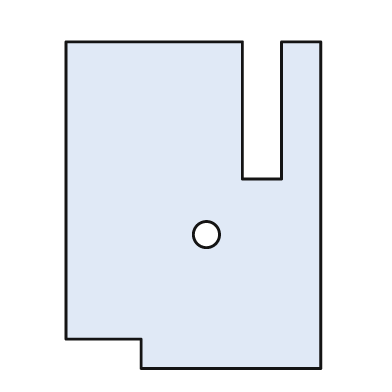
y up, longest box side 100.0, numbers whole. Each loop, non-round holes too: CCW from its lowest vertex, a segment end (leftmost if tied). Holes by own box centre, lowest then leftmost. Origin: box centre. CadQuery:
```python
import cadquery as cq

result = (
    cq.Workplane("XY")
    .moveTo(-16.0, -50.0)
    .lineTo(39.0, -50.0)
    .lineTo(39.0, 50.0)
    .lineTo(27.0, 50.0)
    .lineTo(27.0, 8.0)
    .lineTo(15.0, 8.0)
    .lineTo(15.0, 50.0)
    .lineTo(-39.0, 50.0)
    .lineTo(-39.0, -41.0)
    .lineTo(-16.0, -41.0)
    .close()
    .moveTo(4.0, -9.0)
    .circle(4.0)
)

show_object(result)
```